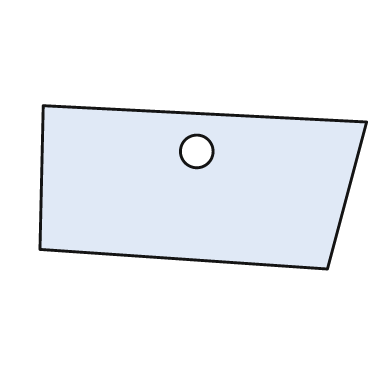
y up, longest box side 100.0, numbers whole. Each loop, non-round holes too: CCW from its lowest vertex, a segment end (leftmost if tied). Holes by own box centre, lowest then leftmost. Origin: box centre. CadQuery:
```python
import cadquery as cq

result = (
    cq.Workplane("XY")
    .moveTo(38.0, -25.0)
    .lineTo(50.0, 20.0)
    .lineTo(-49.0, 25.0)
    .lineTo(-50.0, -19.0)
    .close()
    .moveTo(-2.0, 11.0)
    .circle(5.0)
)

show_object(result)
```